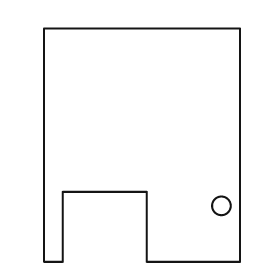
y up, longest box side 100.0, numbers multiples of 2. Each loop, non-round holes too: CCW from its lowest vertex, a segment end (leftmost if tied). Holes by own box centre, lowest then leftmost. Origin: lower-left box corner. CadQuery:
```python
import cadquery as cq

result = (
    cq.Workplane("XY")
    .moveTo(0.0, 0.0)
    .lineTo(8.0, 0.0)
    .lineTo(8.0, 30.0)
    .lineTo(44.0, 30.0)
    .lineTo(44.0, 0.0)
    .lineTo(84.0, 0.0)
    .lineTo(84.0, 100.0)
    .lineTo(0.0, 100.0)
    .close()
    .moveTo(76.0, 24.0)
    .circle(4.0)
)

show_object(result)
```